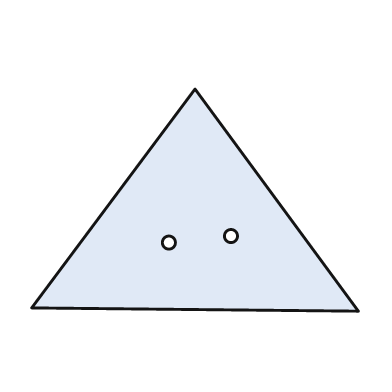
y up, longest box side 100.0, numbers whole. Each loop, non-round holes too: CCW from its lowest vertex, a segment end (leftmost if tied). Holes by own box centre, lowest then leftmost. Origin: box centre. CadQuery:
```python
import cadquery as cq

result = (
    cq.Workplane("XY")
    .moveTo(50.0, -34.0)
    .lineTo(0.0, 34.0)
    .lineTo(-50.0, -33.0)
    .close()
    .moveTo(-8.0, -13.0)
    .circle(2.0)
    .moveTo(11.0, -11.0)
    .circle(2.0)
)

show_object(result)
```